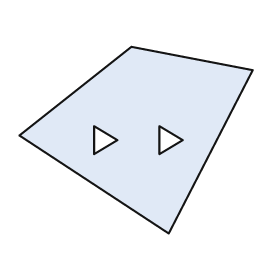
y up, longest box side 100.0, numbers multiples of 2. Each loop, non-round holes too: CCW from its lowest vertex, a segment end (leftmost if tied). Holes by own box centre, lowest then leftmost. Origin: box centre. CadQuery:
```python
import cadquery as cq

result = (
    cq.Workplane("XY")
    .moveTo(14.0, -40.0)
    .lineTo(50.0, 30.0)
    .lineTo(-2.0, 40.0)
    .lineTo(-50.0, 2.0)
    .close()
    .moveTo(-18.0, -6.0)
    .lineTo(-8.0, 0.0)
    .lineTo(-18.0, 6.0)
    .close()
    .moveTo(10.0, -6.0)
    .lineTo(20.0, 0.0)
    .lineTo(10.0, 6.0)
    .close()
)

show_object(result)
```